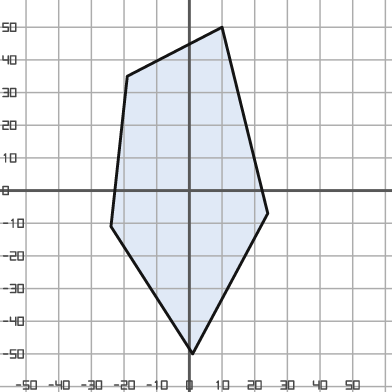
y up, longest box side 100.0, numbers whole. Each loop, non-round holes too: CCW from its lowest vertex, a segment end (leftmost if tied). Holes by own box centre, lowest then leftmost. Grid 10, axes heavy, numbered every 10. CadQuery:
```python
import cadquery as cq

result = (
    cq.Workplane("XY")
    .moveTo(1.0, -50.0)
    .lineTo(24.0, -7.0)
    .lineTo(10.0, 50.0)
    .lineTo(-19.0, 35.0)
    .lineTo(-24.0, -11.0)
    .close()
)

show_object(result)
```